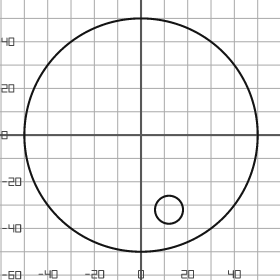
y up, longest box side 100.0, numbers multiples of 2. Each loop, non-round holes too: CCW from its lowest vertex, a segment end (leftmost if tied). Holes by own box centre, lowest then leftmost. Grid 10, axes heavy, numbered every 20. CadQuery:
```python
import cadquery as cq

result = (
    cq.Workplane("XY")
    .moveTo(0.0, 0.0)
    .circle(50.0)
    .moveTo(12.0, -32.0)
    .circle(6.0)
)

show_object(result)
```